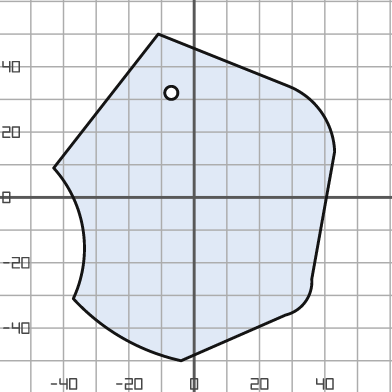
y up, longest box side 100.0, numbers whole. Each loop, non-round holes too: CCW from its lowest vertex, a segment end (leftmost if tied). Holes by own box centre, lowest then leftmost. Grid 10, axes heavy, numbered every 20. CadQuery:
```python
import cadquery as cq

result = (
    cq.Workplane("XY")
    .moveTo(-4.0, -50.0)
    .lineTo(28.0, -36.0)
    .threePointArc((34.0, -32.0), (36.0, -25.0))
    .lineTo(43.0, 14.0)
    .threePointArc((39.0, 26.0), (29.0, 34.0))
    .lineTo(-11.0, 50.0)
    .lineTo(-43.0, 9.0)
    .threePointArc((-34.0, -10.0), (-37.0, -31.0))
    .threePointArc((-22.0, -43.0), (-4.0, -50.0))
    .close()
    .moveTo(-7.0, 32.0)
    .circle(2.0)
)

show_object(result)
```